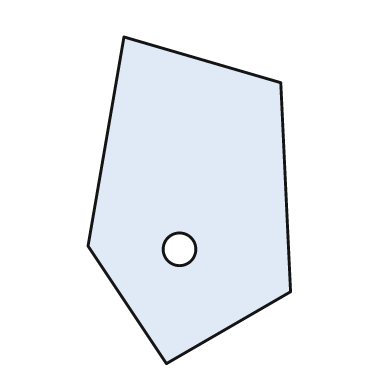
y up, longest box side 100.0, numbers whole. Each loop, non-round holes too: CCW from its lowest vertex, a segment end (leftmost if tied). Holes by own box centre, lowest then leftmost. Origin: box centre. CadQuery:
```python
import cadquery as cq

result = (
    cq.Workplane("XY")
    .moveTo(-7.0, -50.0)
    .lineTo(31.0, -28.0)
    .lineTo(28.0, 36.0)
    .lineTo(-20.0, 50.0)
    .lineTo(-31.0, -14.0)
    .close()
    .moveTo(-3.0, -15.0)
    .circle(5.0)
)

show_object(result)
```